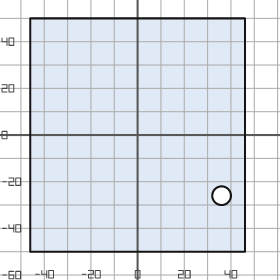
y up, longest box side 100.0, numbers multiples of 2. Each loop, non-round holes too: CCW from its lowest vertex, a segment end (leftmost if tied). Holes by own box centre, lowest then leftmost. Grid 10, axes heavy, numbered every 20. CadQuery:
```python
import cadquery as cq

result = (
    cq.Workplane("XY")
    .moveTo(-46.0, -50.0)
    .lineTo(46.0, -50.0)
    .lineTo(46.0, 50.0)
    .lineTo(-46.0, 50.0)
    .close()
    .moveTo(36.0, -26.0)
    .circle(4.0)
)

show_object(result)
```